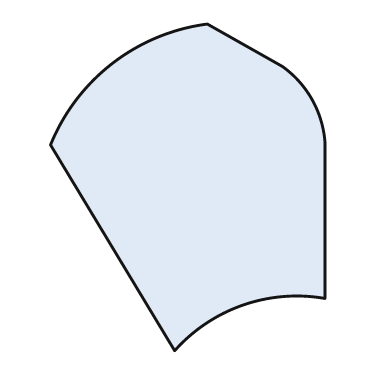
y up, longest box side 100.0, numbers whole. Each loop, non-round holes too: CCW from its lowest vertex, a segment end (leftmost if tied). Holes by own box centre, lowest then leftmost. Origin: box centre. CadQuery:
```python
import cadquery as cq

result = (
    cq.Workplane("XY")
    .moveTo(-4.0, -50.0)
    .threePointArc((17.0, -36.0), (42.0, -34.0))
    .lineTo(42.0, 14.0)
    .threePointArc((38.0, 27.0), (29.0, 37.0))
    .lineTo(6.0, 50.0)
    .threePointArc((-23.0, 38.0), (-42.0, 13.0))
    .close()
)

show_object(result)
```